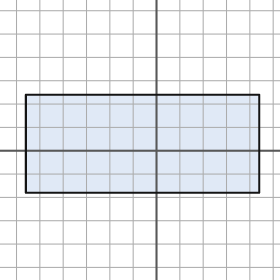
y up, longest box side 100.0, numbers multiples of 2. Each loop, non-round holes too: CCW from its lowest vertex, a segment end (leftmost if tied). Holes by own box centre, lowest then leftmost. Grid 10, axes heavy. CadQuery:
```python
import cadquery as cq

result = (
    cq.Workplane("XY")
    .moveTo(-56.0, -18.0)
    .lineTo(44.0, -18.0)
    .lineTo(44.0, 24.0)
    .lineTo(-56.0, 24.0)
    .close()
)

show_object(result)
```